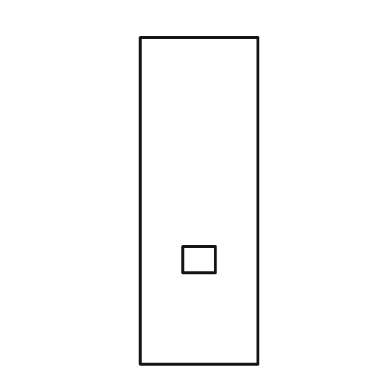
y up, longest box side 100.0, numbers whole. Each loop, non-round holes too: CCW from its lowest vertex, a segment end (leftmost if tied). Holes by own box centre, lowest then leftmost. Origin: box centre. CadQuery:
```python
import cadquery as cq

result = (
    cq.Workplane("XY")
    .moveTo(-18.0, -50.0)
    .lineTo(18.0, -50.0)
    .lineTo(18.0, 50.0)
    .lineTo(-18.0, 50.0)
    .close()
    .moveTo(-5.0, -22.0)
    .lineTo(5.0, -22.0)
    .lineTo(5.0, -14.0)
    .lineTo(-5.0, -14.0)
    .close()
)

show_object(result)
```